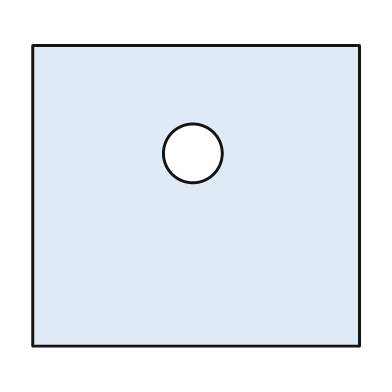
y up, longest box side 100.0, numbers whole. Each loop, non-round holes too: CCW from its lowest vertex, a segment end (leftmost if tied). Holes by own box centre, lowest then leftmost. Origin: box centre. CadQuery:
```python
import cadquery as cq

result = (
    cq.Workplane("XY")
    .moveTo(-50.0, -46.0)
    .lineTo(50.0, -46.0)
    .lineTo(50.0, 46.0)
    .lineTo(-50.0, 46.0)
    .close()
    .moveTo(-1.0, 13.0)
    .circle(9.0)
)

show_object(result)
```